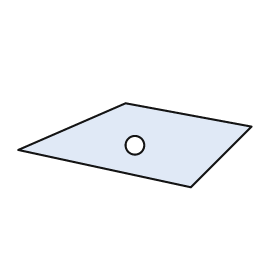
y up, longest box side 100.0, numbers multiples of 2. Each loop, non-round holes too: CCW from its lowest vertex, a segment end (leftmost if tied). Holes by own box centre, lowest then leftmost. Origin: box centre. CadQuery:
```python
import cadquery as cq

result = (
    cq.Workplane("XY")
    .moveTo(24.0, -18.0)
    .lineTo(50.0, 8.0)
    .lineTo(-4.0, 18.0)
    .lineTo(-50.0, -2.0)
    .close()
    .moveTo(0.0, 0.0)
    .circle(4.0)
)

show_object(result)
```